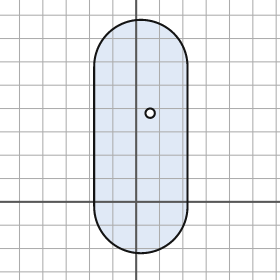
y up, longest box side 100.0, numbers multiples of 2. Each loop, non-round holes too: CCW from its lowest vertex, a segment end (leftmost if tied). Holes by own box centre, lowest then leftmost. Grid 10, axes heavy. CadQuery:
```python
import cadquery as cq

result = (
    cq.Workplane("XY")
    .moveTo(-18.0, -2.0)
    .threePointArc((2.0, -22.0), (22.0, -2.0))
    .lineTo(22.0, 58.0)
    .threePointArc((2.0, 78.0), (-18.0, 58.0))
    .close()
    .moveTo(6.0, 38.0)
    .circle(2.0)
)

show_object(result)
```